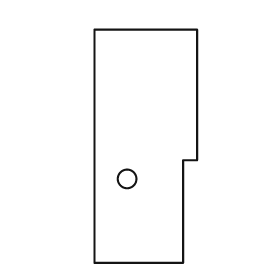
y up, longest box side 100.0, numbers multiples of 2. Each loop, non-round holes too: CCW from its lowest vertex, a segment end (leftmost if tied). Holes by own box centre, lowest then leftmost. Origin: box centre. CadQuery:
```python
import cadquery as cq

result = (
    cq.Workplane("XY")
    .moveTo(-22.0, -50.0)
    .lineTo(16.0, -50.0)
    .lineTo(16.0, -6.0)
    .lineTo(22.0, -6.0)
    .lineTo(22.0, 50.0)
    .lineTo(-22.0, 50.0)
    .close()
    .moveTo(-8.0, -14.0)
    .circle(4.0)
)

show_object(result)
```